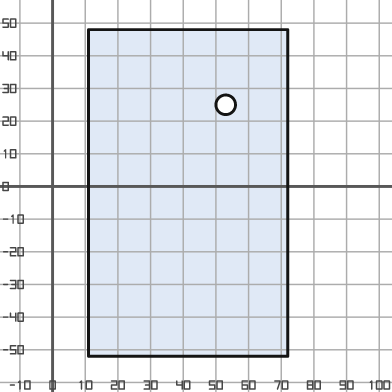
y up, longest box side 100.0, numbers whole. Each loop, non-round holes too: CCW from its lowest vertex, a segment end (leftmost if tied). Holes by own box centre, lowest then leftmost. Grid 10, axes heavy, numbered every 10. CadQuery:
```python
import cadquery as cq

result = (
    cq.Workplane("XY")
    .moveTo(11.0, -52.0)
    .lineTo(72.0, -52.0)
    .lineTo(72.0, 48.0)
    .lineTo(11.0, 48.0)
    .close()
    .moveTo(53.0, 25.0)
    .circle(3.0)
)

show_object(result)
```